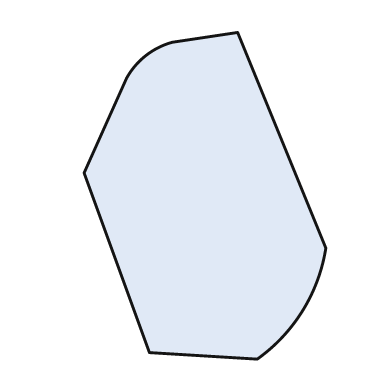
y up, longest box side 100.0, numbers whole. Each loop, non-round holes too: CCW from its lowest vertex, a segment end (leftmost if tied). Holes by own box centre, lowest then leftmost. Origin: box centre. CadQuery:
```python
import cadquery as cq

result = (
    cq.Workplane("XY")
    .moveTo(16.0, -50.0)
    .threePointArc((30.0, -35.0), (37.0, -16.0))
    .lineTo(10.0, 50.0)
    .lineTo(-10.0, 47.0)
    .threePointArc((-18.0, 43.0), (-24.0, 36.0))
    .lineTo(-37.0, 7.0)
    .lineTo(-17.0, -48.0)
    .close()
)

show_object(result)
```